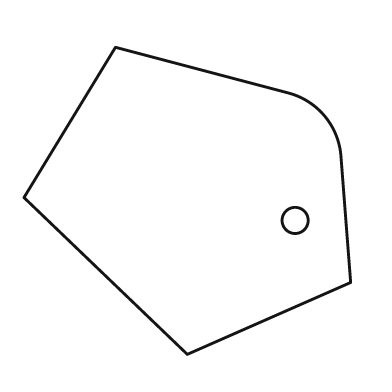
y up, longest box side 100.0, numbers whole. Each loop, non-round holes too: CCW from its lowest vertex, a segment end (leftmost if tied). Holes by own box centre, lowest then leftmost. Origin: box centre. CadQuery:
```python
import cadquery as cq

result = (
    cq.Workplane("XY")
    .moveTo(0.0, -47.0)
    .lineTo(50.0, -25.0)
    .lineTo(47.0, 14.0)
    .threePointArc((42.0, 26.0), (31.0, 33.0))
    .lineTo(-22.0, 47.0)
    .lineTo(-50.0, 1.0)
    .close()
    .moveTo(33.0, -6.0)
    .circle(4.0)
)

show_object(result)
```